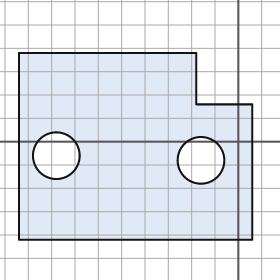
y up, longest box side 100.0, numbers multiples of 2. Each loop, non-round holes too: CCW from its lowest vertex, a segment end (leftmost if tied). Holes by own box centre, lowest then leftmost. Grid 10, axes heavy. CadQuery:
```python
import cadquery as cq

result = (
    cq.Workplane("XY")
    .moveTo(-94.0, -42.0)
    .lineTo(6.0, -42.0)
    .lineTo(6.0, 16.0)
    .lineTo(-18.0, 16.0)
    .lineTo(-18.0, 38.0)
    .lineTo(-94.0, 38.0)
    .close()
    .moveTo(-16.0, -8.0)
    .circle(10.0)
    .moveTo(-78.0, -6.0)
    .circle(10.0)
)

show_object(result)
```